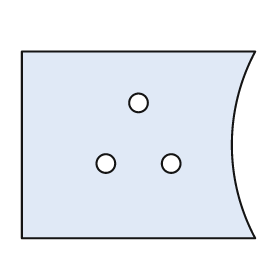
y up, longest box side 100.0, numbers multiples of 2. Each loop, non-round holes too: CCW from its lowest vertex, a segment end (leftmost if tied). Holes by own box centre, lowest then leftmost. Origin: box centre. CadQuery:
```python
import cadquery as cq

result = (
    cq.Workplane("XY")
    .moveTo(-50.0, -40.0)
    .lineTo(50.0, -40.0)
    .threePointArc((40.0, 0.0), (50.0, 40.0))
    .lineTo(-50.0, 40.0)
    .close()
    .moveTo(-14.0, -8.0)
    .circle(4.0)
    .moveTo(14.0, -8.0)
    .circle(4.0)
    .moveTo(0.0, 18.0)
    .circle(4.0)
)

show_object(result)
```